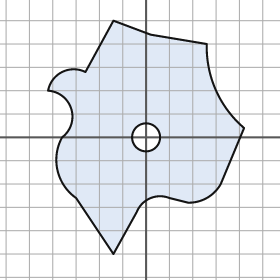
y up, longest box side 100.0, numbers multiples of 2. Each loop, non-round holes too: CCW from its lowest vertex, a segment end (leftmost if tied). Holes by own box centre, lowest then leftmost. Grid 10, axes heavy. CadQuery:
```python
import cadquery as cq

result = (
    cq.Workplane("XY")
    .moveTo(-14.0, -50.0)
    .lineTo(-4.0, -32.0)
    .threePointArc((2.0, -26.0), (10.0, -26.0))
    .lineTo(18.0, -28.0)
    .threePointArc((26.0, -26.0), (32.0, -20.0))
    .lineTo(42.0, 4.0)
    .threePointArc((30.0, 20.0), (26.0, 40.0))
    .lineTo(2.0, 44.0)
    .lineTo(-14.0, 50.0)
    .lineTo(-26.0, 28.0)
    .threePointArc((-36.0, 28.0), (-42.0, 20.0))
    .threePointArc((-32.0, 12.0), (-36.0, 0.0))
    .threePointArc((-38.0, -14.0), (-30.0, -26.0))
    .close()
    .moveTo(0.0, 0.0)
    .circle(6.0)
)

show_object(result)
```